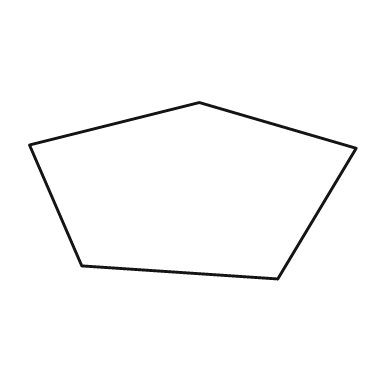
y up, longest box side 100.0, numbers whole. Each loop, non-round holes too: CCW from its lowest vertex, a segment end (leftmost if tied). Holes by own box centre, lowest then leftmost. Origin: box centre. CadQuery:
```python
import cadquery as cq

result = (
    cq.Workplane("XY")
    .moveTo(26.0, -27.0)
    .lineTo(50.0, 13.0)
    .lineTo(2.0, 27.0)
    .lineTo(-50.0, 14.0)
    .lineTo(-34.0, -23.0)
    .close()
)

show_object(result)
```